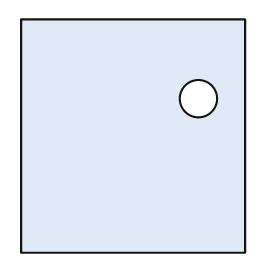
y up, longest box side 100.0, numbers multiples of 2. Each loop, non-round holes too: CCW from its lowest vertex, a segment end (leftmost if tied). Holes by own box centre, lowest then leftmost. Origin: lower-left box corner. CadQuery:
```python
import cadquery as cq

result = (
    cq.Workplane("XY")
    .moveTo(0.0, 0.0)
    .lineTo(96.0, 0.0)
    .lineTo(96.0, 100.0)
    .lineTo(0.0, 100.0)
    .close()
    .moveTo(76.0, 66.0)
    .circle(8.0)
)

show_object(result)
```